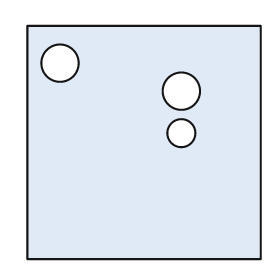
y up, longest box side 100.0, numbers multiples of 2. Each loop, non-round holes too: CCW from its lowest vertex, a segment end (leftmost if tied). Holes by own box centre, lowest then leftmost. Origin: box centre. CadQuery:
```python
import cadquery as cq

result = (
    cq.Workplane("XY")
    .moveTo(-50.0, -50.0)
    .lineTo(50.0, -50.0)
    .lineTo(50.0, 50.0)
    .lineTo(-50.0, 50.0)
    .close()
    .moveTo(16.0, 4.0)
    .circle(6.0)
    .moveTo(16.0, 22.0)
    .circle(8.0)
    .moveTo(-36.0, 34.0)
    .circle(8.0)
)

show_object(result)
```